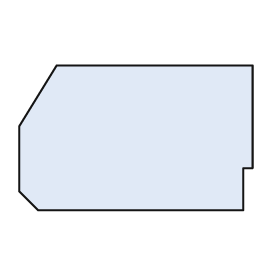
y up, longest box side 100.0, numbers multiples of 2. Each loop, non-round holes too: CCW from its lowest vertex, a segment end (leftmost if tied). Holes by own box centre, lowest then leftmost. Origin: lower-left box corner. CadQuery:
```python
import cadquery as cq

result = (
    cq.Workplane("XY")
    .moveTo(8.0, 0.0)
    .lineTo(96.0, 0.0)
    .lineTo(96.0, 18.0)
    .lineTo(100.0, 18.0)
    .lineTo(100.0, 62.0)
    .lineTo(16.0, 62.0)
    .lineTo(0.0, 36.0)
    .lineTo(0.0, 8.0)
    .close()
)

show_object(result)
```